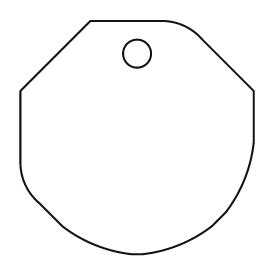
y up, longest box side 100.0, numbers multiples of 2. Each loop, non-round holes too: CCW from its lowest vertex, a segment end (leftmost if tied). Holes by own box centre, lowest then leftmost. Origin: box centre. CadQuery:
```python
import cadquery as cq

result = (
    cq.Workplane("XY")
    .moveTo(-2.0, -50.0)
    .lineTo(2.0, -50.0)
    .threePointArc((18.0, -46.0), (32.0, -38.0))
    .lineTo(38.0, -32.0)
    .threePointArc((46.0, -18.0), (50.0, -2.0))
    .lineTo(50.0, 20.0)
    .lineTo(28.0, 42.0)
    .threePointArc((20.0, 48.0), (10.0, 50.0))
    .lineTo(-20.0, 50.0)
    .lineTo(-50.0, 20.0)
    .lineTo(-50.0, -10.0)
    .threePointArc((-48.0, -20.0), (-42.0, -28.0))
    .lineTo(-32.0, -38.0)
    .threePointArc((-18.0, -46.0), (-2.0, -50.0))
    .close()
    .moveTo(0.0, 36.0)
    .circle(6.0)
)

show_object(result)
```